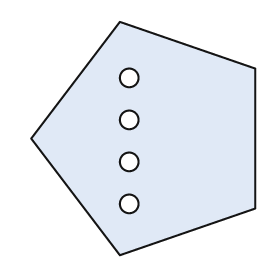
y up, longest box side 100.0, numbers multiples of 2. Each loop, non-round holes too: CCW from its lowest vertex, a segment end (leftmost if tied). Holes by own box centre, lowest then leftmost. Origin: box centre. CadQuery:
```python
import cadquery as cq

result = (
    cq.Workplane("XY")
    .moveTo(-10.0, -50.0)
    .lineTo(48.0, -30.0)
    .lineTo(48.0, 30.0)
    .lineTo(-10.0, 50.0)
    .lineTo(-48.0, 0.0)
    .close()
    .moveTo(-6.0, -28.0)
    .circle(4.0)
    .moveTo(-6.0, -10.0)
    .circle(4.0)
    .moveTo(-6.0, 8.0)
    .circle(4.0)
    .moveTo(-6.0, 26.0)
    .circle(4.0)
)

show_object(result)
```